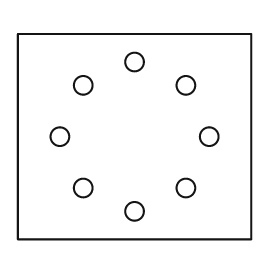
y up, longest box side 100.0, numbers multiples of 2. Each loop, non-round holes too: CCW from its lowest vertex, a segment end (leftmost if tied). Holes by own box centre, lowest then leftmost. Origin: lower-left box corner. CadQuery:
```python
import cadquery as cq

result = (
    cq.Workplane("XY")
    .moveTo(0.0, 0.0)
    .lineTo(100.0, 0.0)
    .lineTo(100.0, 88.0)
    .lineTo(0.0, 88.0)
    .close()
    .moveTo(50.0, 12.0)
    .circle(4.0)
    .moveTo(28.0, 22.0)
    .circle(4.0)
    .moveTo(72.0, 22.0)
    .circle(4.0)
    .moveTo(18.0, 44.0)
    .circle(4.0)
    .moveTo(82.0, 44.0)
    .circle(4.0)
    .moveTo(28.0, 66.0)
    .circle(4.0)
    .moveTo(72.0, 66.0)
    .circle(4.0)
    .moveTo(50.0, 76.0)
    .circle(4.0)
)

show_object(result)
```